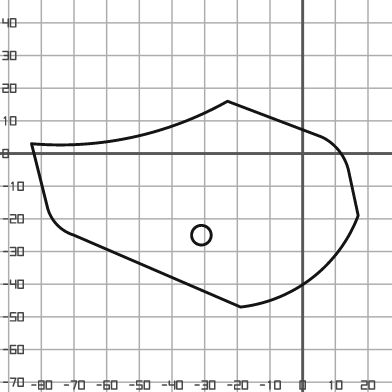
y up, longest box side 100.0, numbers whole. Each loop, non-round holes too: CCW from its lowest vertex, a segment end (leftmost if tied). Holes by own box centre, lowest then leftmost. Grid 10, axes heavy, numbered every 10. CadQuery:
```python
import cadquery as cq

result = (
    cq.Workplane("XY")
    .moveTo(-19.0, -47.0)
    .threePointArc((3.0, -38.0), (17.0, -19.0))
    .lineTo(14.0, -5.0)
    .threePointArc((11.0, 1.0), (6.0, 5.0))
    .lineTo(-23.0, 16.0)
    .threePointArc((-52.0, 5.0), (-83.0, 3.0))
    .lineTo(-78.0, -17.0)
    .threePointArc((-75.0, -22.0), (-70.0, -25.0))
    .close()
    .moveTo(-31.0, -25.0)
    .circle(3.0)
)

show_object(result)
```